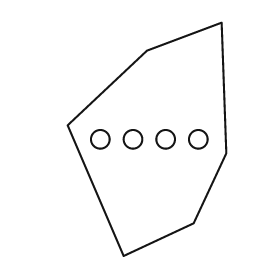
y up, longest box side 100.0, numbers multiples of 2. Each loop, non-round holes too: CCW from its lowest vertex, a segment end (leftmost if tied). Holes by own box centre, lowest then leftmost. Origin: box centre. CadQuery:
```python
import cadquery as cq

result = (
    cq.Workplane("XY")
    .moveTo(-10.0, -50.0)
    .lineTo(20.0, -36.0)
    .lineTo(34.0, -6.0)
    .lineTo(32.0, 50.0)
    .lineTo(0.0, 38.0)
    .lineTo(-34.0, 6.0)
    .close()
    .moveTo(-20.0, 0.0)
    .circle(4.0)
    .moveTo(-6.0, 0.0)
    .circle(4.0)
    .moveTo(8.0, 0.0)
    .circle(4.0)
    .moveTo(22.0, 0.0)
    .circle(4.0)
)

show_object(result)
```